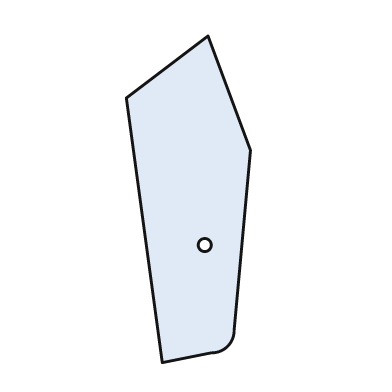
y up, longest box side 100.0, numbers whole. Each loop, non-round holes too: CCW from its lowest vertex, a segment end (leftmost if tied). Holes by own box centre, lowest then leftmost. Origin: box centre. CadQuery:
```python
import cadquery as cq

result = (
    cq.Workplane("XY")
    .moveTo(-8.0, -50.0)
    .lineTo(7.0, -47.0)
    .threePointArc((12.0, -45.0), (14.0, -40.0))
    .lineTo(19.0, 15.0)
    .lineTo(6.0, 50.0)
    .lineTo(-19.0, 31.0)
    .close()
    .moveTo(5.0, -14.0)
    .circle(2.0)
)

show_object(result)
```